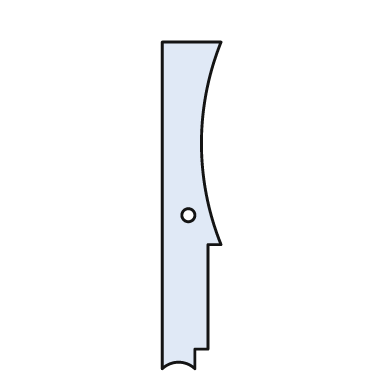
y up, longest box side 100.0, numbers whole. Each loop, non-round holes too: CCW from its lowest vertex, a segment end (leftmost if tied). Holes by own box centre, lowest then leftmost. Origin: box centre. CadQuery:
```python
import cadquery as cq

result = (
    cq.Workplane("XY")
    .moveTo(-9.0, -50.0)
    .threePointArc((-4.0, -48.0), (1.0, -50.0))
    .lineTo(1.0, -44.0)
    .lineTo(5.0, -44.0)
    .lineTo(5.0, -12.0)
    .lineTo(9.0, -12.0)
    .threePointArc((3.0, 19.0), (9.0, 50.0))
    .lineTo(-9.0, 50.0)
    .close()
    .moveTo(-1.0, -3.0)
    .circle(2.0)
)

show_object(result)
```